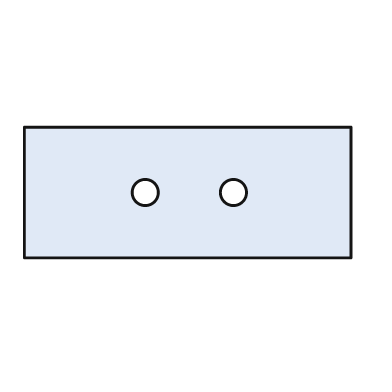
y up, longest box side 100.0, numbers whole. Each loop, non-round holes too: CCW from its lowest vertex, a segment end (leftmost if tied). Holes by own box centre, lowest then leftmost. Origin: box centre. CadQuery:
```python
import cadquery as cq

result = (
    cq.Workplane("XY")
    .moveTo(-50.0, -20.0)
    .lineTo(50.0, -20.0)
    .lineTo(50.0, 20.0)
    .lineTo(-50.0, 20.0)
    .close()
    .moveTo(-13.0, 0.0)
    .circle(4.0)
    .moveTo(14.0, 0.0)
    .circle(4.0)
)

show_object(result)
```